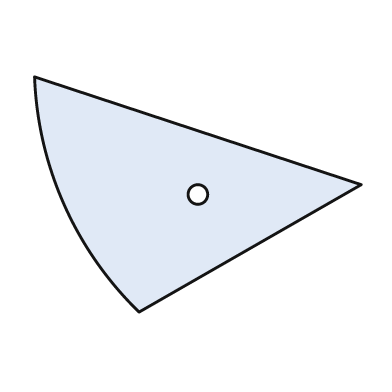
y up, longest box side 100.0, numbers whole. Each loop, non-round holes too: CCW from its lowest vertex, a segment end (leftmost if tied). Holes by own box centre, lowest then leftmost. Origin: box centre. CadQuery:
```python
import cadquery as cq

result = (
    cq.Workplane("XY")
    .moveTo(-18.0, -36.0)
    .lineTo(50.0, 3.0)
    .lineTo(-50.0, 36.0)
    .threePointArc((-41.0, -3.0), (-18.0, -36.0))
    .close()
    .moveTo(0.0, 0.0)
    .circle(3.0)
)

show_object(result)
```